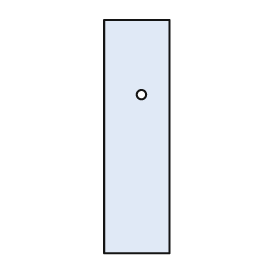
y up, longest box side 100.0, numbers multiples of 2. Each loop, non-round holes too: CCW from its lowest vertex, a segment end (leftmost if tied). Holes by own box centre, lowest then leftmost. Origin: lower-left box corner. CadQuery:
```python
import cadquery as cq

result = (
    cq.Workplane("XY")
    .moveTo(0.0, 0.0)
    .lineTo(28.0, 0.0)
    .lineTo(28.0, 100.0)
    .lineTo(0.0, 100.0)
    .close()
    .moveTo(16.0, 68.0)
    .circle(2.0)
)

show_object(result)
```